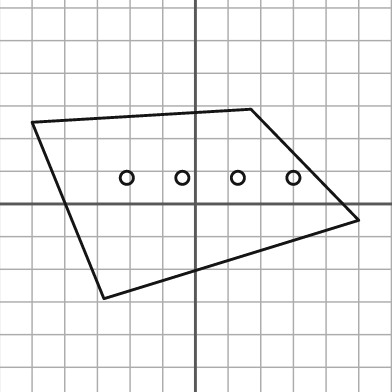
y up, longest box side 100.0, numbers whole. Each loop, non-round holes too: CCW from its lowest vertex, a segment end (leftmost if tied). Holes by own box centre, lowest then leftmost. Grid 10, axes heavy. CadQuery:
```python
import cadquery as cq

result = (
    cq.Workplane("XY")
    .moveTo(-28.0, -29.0)
    .lineTo(50.0, -5.0)
    .lineTo(17.0, 29.0)
    .lineTo(-50.0, 25.0)
    .close()
    .moveTo(-21.0, 8.0)
    .circle(2.0)
    .moveTo(-4.0, 8.0)
    .circle(2.0)
    .moveTo(13.0, 8.0)
    .circle(2.0)
    .moveTo(30.0, 8.0)
    .circle(2.0)
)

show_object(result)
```